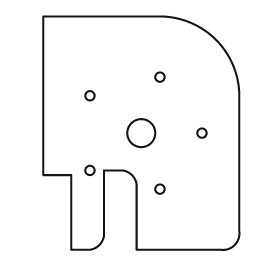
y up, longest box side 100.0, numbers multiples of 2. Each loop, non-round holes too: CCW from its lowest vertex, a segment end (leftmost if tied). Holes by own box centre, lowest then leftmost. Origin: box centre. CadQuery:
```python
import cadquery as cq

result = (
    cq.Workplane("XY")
    .moveTo(-30.0, -50.0)
    .lineTo(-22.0, -50.0)
    .threePointArc((-18.0, -48.0), (-16.0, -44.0))
    .lineTo(-16.0, -16.0)
    .lineTo(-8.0, -16.0)
    .threePointArc((-4.0, -18.0), (-2.0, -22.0))
    .lineTo(-2.0, -50.0)
    .lineTo(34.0, -50.0)
    .threePointArc((40.0, -48.0), (42.0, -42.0))
    .lineTo(42.0, 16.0)
    .threePointArc((32.0, 40.0), (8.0, 50.0))
    .lineTo(-42.0, 50.0)
    .lineTo(-42.0, -18.0)
    .lineTo(-30.0, -18.0)
    .close()
    .moveTo(8.0, -24.0)
    .circle(2.0)
    .moveTo(-22.0, -16.0)
    .circle(2.0)
    .moveTo(0.0, 0.0)
    .circle(6.0)
    .moveTo(26.0, 0.0)
    .circle(2.0)
    .moveTo(-22.0, 16.0)
    .circle(2.0)
    .moveTo(8.0, 24.0)
    .circle(2.0)
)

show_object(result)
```